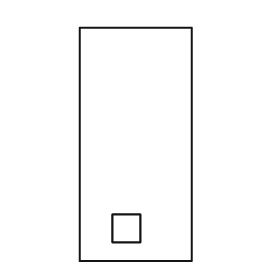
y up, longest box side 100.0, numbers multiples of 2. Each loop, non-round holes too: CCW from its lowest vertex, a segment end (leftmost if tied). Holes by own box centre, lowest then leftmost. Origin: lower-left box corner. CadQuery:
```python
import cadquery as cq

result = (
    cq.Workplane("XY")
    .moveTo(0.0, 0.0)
    .lineTo(48.0, 0.0)
    .lineTo(48.0, 100.0)
    .lineTo(0.0, 100.0)
    .close()
    .moveTo(14.0, 8.0)
    .lineTo(26.0, 8.0)
    .lineTo(26.0, 20.0)
    .lineTo(14.0, 20.0)
    .close()
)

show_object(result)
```